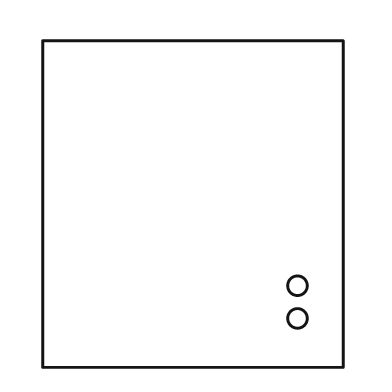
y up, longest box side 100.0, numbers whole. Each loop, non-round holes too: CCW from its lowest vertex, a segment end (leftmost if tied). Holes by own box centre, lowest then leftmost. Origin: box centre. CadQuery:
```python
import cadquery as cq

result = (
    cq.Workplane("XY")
    .moveTo(-46.0, -50.0)
    .lineTo(46.0, -50.0)
    .lineTo(46.0, 50.0)
    .lineTo(-46.0, 50.0)
    .close()
    .moveTo(32.0, -35.0)
    .circle(3.0)
    .moveTo(32.0, -25.0)
    .circle(3.0)
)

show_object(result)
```